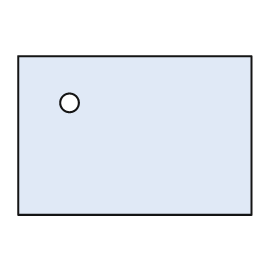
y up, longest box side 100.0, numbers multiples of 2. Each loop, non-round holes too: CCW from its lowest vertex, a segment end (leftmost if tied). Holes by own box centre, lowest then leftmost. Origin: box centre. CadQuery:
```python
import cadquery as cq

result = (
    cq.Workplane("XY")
    .moveTo(-50.0, -34.0)
    .lineTo(50.0, -34.0)
    .lineTo(50.0, 34.0)
    .lineTo(-50.0, 34.0)
    .close()
    .moveTo(-28.0, 14.0)
    .circle(4.0)
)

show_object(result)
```